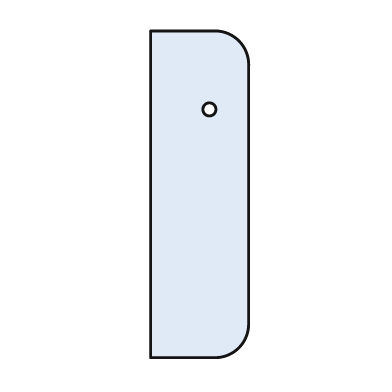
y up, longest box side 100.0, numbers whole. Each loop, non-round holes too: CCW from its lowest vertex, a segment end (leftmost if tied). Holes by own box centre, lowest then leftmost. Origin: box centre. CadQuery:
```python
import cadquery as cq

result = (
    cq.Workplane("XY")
    .moveTo(-15.0, -50.0)
    .lineTo(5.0, -50.0)
    .threePointArc((12.0, -47.0), (15.0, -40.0))
    .lineTo(15.0, 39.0)
    .threePointArc((12.0, 47.0), (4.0, 50.0))
    .lineTo(-15.0, 50.0)
    .close()
    .moveTo(3.0, 26.0)
    .circle(2.0)
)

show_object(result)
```